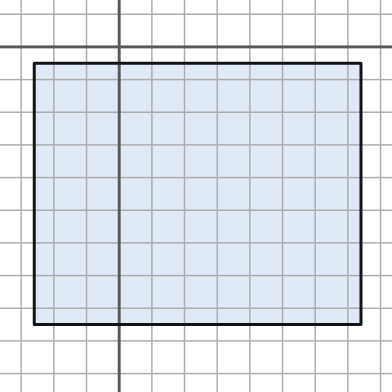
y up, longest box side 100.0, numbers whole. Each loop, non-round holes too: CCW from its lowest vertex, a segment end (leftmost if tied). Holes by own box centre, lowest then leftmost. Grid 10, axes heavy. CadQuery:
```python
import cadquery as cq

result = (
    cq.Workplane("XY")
    .moveTo(-26.0, -85.0)
    .lineTo(74.0, -85.0)
    .lineTo(74.0, -5.0)
    .lineTo(-26.0, -5.0)
    .close()
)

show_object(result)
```